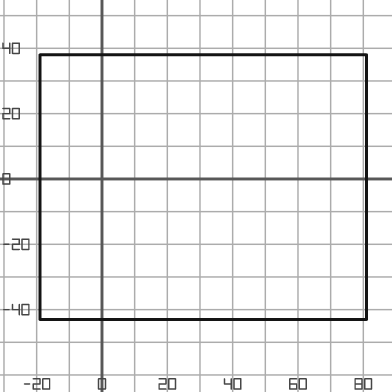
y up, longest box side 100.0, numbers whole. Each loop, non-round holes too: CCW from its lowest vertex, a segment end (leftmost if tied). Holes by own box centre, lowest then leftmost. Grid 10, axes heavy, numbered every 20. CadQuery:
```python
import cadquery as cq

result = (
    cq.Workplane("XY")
    .moveTo(-19.0, -43.0)
    .lineTo(81.0, -43.0)
    .lineTo(81.0, 38.0)
    .lineTo(-19.0, 38.0)
    .close()
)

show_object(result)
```